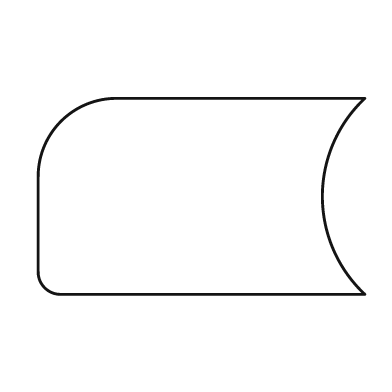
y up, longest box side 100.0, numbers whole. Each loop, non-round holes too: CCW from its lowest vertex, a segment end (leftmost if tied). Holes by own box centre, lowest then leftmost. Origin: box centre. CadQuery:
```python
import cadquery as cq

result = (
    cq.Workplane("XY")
    .moveTo(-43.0, -30.0)
    .lineTo(50.0, -30.0)
    .threePointArc((37.0, 0.0), (50.0, 30.0))
    .lineTo(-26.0, 30.0)
    .threePointArc((-43.0, 23.0), (-50.0, 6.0))
    .lineTo(-50.0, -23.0)
    .threePointArc((-48.0, -28.0), (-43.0, -30.0))
    .close()
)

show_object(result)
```